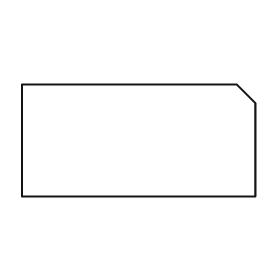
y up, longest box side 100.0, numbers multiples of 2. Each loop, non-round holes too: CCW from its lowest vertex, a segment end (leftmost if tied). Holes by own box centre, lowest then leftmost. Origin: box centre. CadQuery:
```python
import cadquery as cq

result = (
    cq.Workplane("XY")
    .moveTo(-50.0, -24.0)
    .lineTo(50.0, -24.0)
    .lineTo(50.0, 16.0)
    .lineTo(42.0, 24.0)
    .lineTo(-50.0, 24.0)
    .close()
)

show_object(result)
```